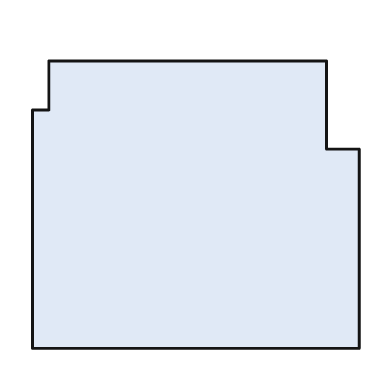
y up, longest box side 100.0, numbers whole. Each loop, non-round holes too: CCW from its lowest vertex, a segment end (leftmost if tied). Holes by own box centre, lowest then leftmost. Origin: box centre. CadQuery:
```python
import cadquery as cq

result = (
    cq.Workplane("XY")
    .moveTo(-50.0, -44.0)
    .lineTo(50.0, -44.0)
    .lineTo(50.0, 17.0)
    .lineTo(40.0, 17.0)
    .lineTo(40.0, 44.0)
    .lineTo(-45.0, 44.0)
    .lineTo(-45.0, 29.0)
    .lineTo(-50.0, 29.0)
    .close()
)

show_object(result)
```